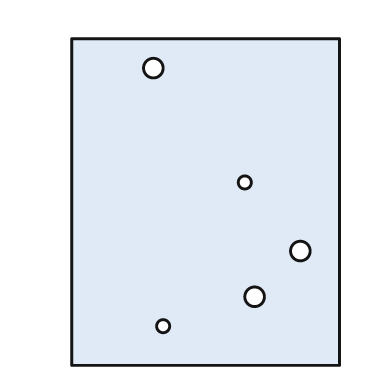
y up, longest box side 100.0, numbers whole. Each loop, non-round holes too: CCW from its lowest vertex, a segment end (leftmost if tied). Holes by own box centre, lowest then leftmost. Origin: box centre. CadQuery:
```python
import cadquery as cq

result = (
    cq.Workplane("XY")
    .moveTo(-41.0, -50.0)
    .lineTo(41.0, -50.0)
    .lineTo(41.0, 50.0)
    .lineTo(-41.0, 50.0)
    .close()
    .moveTo(-13.0, -38.0)
    .circle(2.0)
    .moveTo(15.0, -29.0)
    .circle(3.0)
    .moveTo(29.0, -15.0)
    .circle(3.0)
    .moveTo(12.0, 6.0)
    .circle(2.0)
    .moveTo(-16.0, 41.0)
    .circle(3.0)
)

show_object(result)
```